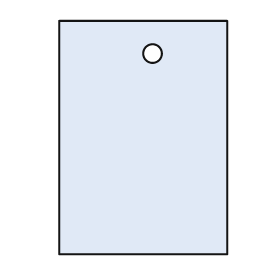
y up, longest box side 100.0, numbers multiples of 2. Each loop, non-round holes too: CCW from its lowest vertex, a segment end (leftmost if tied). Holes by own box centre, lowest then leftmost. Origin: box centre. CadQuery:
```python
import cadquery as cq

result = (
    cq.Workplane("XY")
    .moveTo(-36.0, -50.0)
    .lineTo(36.0, -50.0)
    .lineTo(36.0, 50.0)
    .lineTo(-36.0, 50.0)
    .close()
    .moveTo(4.0, 36.0)
    .circle(4.0)
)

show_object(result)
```